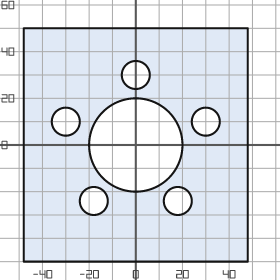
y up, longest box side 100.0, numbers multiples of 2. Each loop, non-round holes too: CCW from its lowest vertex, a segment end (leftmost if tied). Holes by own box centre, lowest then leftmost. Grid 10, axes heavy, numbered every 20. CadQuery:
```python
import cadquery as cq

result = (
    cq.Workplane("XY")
    .moveTo(-48.0, -50.0)
    .lineTo(48.0, -50.0)
    .lineTo(48.0, 50.0)
    .lineTo(-48.0, 50.0)
    .close()
    .moveTo(-18.0, -24.0)
    .circle(6.0)
    .moveTo(18.0, -24.0)
    .circle(6.0)
    .moveTo(0.0, 0.0)
    .circle(20.0)
    .moveTo(-30.0, 10.0)
    .circle(6.0)
    .moveTo(30.0, 10.0)
    .circle(6.0)
    .moveTo(0.0, 30.0)
    .circle(6.0)
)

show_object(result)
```